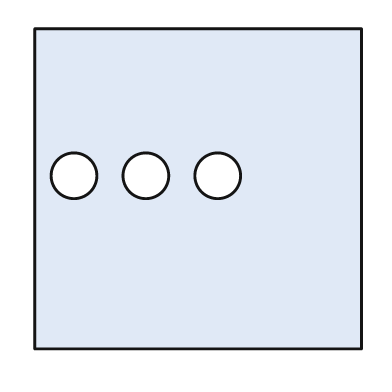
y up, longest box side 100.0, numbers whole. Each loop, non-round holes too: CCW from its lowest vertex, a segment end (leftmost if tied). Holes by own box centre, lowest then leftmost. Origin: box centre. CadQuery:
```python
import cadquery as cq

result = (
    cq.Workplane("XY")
    .moveTo(-50.0, -49.0)
    .lineTo(50.0, -49.0)
    .lineTo(50.0, 49.0)
    .lineTo(-50.0, 49.0)
    .close()
    .moveTo(-38.0, 4.0)
    .circle(7.0)
    .moveTo(-16.0, 4.0)
    .circle(7.0)
    .moveTo(6.0, 4.0)
    .circle(7.0)
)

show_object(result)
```